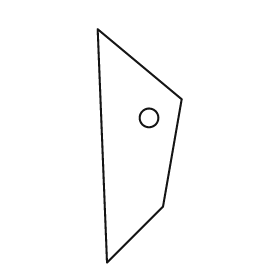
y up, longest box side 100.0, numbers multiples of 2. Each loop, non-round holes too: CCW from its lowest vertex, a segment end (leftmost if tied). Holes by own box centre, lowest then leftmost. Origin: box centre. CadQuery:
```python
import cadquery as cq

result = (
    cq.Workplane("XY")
    .moveTo(-14.0, -50.0)
    .lineTo(10.0, -26.0)
    .lineTo(18.0, 20.0)
    .lineTo(-18.0, 50.0)
    .close()
    .moveTo(4.0, 12.0)
    .circle(4.0)
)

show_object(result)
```